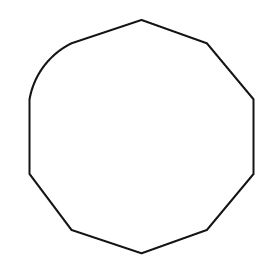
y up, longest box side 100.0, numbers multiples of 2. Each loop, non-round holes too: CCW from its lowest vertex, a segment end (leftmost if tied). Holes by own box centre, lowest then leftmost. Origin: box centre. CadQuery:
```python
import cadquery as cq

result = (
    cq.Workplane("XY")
    .moveTo(0.0, -50.0)
    .lineTo(28.0, -40.0)
    .lineTo(48.0, -16.0)
    .lineTo(48.0, 16.0)
    .lineTo(28.0, 40.0)
    .lineTo(0.0, 50.0)
    .lineTo(-30.0, 40.0)
    .threePointArc((-42.0, 30.0), (-48.0, 16.0))
    .lineTo(-48.0, -16.0)
    .lineTo(-30.0, -40.0)
    .close()
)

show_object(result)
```